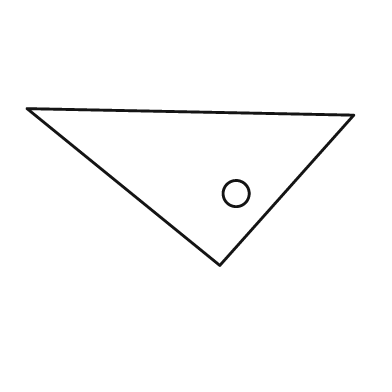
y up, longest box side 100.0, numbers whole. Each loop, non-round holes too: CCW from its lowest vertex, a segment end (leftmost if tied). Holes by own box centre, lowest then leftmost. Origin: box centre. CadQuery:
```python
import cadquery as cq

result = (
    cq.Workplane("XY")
    .moveTo(9.0, -24.0)
    .lineTo(50.0, 22.0)
    .lineTo(-50.0, 24.0)
    .close()
    .moveTo(14.0, -2.0)
    .circle(4.0)
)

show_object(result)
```